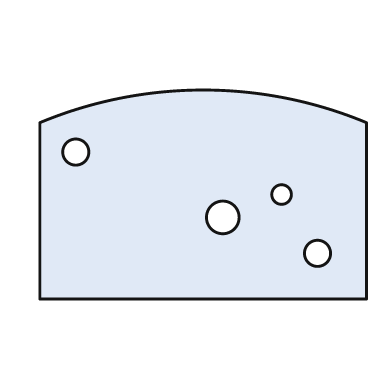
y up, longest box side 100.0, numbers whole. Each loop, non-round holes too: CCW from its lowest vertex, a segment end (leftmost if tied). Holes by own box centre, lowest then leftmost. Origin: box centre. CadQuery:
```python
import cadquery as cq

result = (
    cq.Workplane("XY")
    .moveTo(-50.0, -32.0)
    .lineTo(50.0, -32.0)
    .lineTo(50.0, 22.0)
    .threePointArc((0.0, 32.0), (-50.0, 22.0))
    .close()
    .moveTo(35.0, -18.0)
    .circle(4.0)
    .moveTo(6.0, -7.0)
    .circle(5.0)
    .moveTo(24.0, 0.0)
    .circle(3.0)
    .moveTo(-39.0, 13.0)
    .circle(4.0)
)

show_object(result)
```